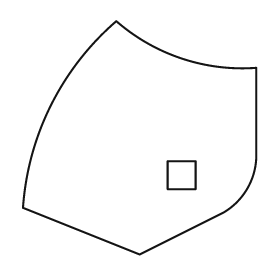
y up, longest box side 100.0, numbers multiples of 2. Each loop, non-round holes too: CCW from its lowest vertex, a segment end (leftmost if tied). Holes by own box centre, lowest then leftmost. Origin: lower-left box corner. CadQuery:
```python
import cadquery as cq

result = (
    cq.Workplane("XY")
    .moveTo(50.0, 0.0)
    .lineTo(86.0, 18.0)
    .threePointArc((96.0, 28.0), (100.0, 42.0))
    .lineTo(100.0, 80.0)
    .threePointArc((68.0, 84.0), (40.0, 100.0))
    .threePointArc((12.0, 64.0), (0.0, 20.0))
    .close()
    .moveTo(62.0, 28.0)
    .lineTo(74.0, 28.0)
    .lineTo(74.0, 40.0)
    .lineTo(62.0, 40.0)
    .close()
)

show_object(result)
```